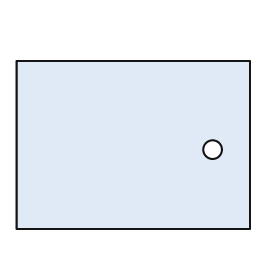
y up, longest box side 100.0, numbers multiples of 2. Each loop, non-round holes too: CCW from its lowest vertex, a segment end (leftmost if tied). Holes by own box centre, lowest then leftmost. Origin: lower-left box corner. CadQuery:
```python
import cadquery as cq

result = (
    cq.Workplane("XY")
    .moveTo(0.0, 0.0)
    .lineTo(100.0, 0.0)
    .lineTo(100.0, 72.0)
    .lineTo(0.0, 72.0)
    .close()
    .moveTo(84.0, 34.0)
    .circle(4.0)
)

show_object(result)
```